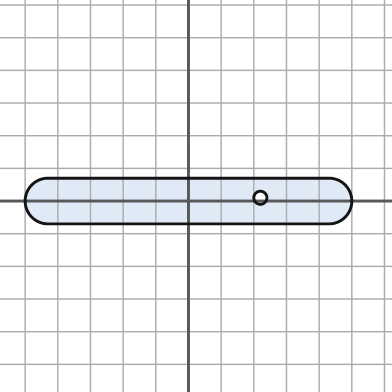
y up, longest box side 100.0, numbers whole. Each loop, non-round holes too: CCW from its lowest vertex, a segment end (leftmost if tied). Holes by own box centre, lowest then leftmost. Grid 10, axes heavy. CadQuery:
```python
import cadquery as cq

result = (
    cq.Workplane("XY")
    .moveTo(-43.0, -7.0)
    .lineTo(43.0, -7.0)
    .threePointArc((50.0, 0.0), (43.0, 7.0))
    .lineTo(-43.0, 7.0)
    .threePointArc((-50.0, 0.0), (-43.0, -7.0))
    .close()
    .moveTo(22.0, 1.0)
    .circle(2.0)
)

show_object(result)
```